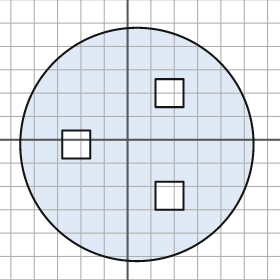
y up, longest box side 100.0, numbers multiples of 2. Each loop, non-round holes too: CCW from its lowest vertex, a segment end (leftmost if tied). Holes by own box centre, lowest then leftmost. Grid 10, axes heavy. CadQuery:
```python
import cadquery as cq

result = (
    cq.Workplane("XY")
    .moveTo(4.0, -2.0)
    .circle(50.0)
    .moveTo(12.0, -30.0)
    .lineTo(24.0, -30.0)
    .lineTo(24.0, -18.0)
    .lineTo(12.0, -18.0)
    .close()
    .moveTo(-28.0, -8.0)
    .lineTo(-16.0, -8.0)
    .lineTo(-16.0, 4.0)
    .lineTo(-28.0, 4.0)
    .close()
    .moveTo(12.0, 14.0)
    .lineTo(24.0, 14.0)
    .lineTo(24.0, 26.0)
    .lineTo(12.0, 26.0)
    .close()
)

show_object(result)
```